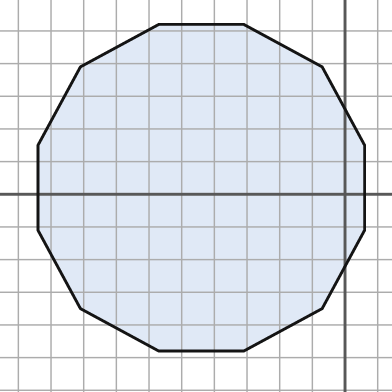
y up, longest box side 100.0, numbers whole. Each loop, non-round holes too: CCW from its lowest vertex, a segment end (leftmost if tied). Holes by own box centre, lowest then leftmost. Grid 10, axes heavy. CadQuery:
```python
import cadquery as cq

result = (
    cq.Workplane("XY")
    .moveTo(-57.0, -48.0)
    .lineTo(-31.0, -48.0)
    .lineTo(-7.0, -35.0)
    .lineTo(6.0, -11.0)
    .lineTo(6.0, 15.0)
    .lineTo(-7.0, 39.0)
    .lineTo(-31.0, 52.0)
    .lineTo(-57.0, 52.0)
    .lineTo(-81.0, 39.0)
    .lineTo(-94.0, 15.0)
    .lineTo(-94.0, -11.0)
    .lineTo(-81.0, -35.0)
    .close()
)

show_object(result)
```